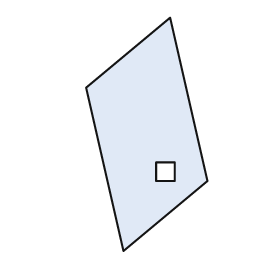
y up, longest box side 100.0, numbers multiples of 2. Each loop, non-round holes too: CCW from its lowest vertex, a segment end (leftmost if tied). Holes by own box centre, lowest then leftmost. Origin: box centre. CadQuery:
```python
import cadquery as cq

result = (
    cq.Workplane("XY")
    .moveTo(-10.0, -50.0)
    .lineTo(26.0, -20.0)
    .lineTo(10.0, 50.0)
    .lineTo(-26.0, 20.0)
    .close()
    .moveTo(4.0, -20.0)
    .lineTo(12.0, -20.0)
    .lineTo(12.0, -12.0)
    .lineTo(4.0, -12.0)
    .close()
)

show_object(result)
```